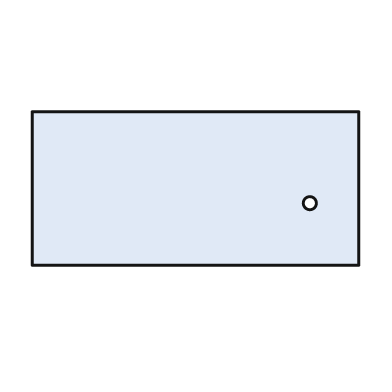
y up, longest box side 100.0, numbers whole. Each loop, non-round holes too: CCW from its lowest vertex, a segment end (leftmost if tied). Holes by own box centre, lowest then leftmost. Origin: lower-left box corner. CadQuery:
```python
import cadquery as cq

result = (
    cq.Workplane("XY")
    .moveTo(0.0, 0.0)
    .lineTo(100.0, 0.0)
    .lineTo(100.0, 47.0)
    .lineTo(0.0, 47.0)
    .close()
    .moveTo(85.0, 19.0)
    .circle(2.0)
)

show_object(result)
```